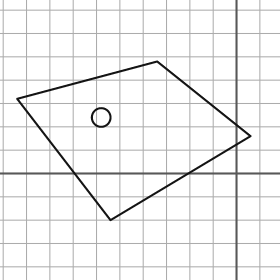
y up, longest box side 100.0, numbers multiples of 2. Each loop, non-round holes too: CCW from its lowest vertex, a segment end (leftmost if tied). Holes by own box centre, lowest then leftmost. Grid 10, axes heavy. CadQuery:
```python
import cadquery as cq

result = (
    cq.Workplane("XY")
    .moveTo(-54.0, -20.0)
    .lineTo(6.0, 16.0)
    .lineTo(-34.0, 48.0)
    .lineTo(-94.0, 32.0)
    .close()
    .moveTo(-58.0, 24.0)
    .circle(4.0)
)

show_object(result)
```